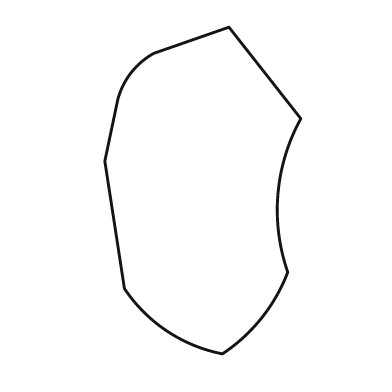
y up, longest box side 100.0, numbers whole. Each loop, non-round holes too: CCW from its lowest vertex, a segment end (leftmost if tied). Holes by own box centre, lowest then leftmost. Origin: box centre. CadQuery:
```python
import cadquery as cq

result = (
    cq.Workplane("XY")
    .moveTo(6.0, -50.0)
    .threePointArc((18.0, -39.0), (26.0, -25.0))
    .threePointArc((23.0, -1.0), (30.0, 22.0))
    .lineTo(8.0, 50.0)
    .lineTo(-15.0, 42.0)
    .threePointArc((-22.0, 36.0), (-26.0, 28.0))
    .lineTo(-30.0, 9.0)
    .lineTo(-24.0, -30.0)
    .threePointArc((-11.0, -43.0), (6.0, -50.0))
    .close()
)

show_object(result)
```